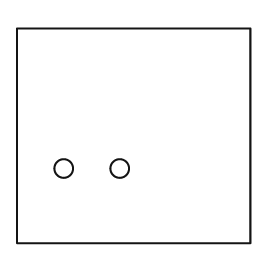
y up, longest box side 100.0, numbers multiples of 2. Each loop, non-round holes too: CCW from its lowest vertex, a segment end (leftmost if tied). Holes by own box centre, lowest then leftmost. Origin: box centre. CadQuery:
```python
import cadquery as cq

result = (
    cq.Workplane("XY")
    .moveTo(-50.0, -46.0)
    .lineTo(50.0, -46.0)
    .lineTo(50.0, 46.0)
    .lineTo(-50.0, 46.0)
    .close()
    .moveTo(-30.0, -14.0)
    .circle(4.0)
    .moveTo(-6.0, -14.0)
    .circle(4.0)
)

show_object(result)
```